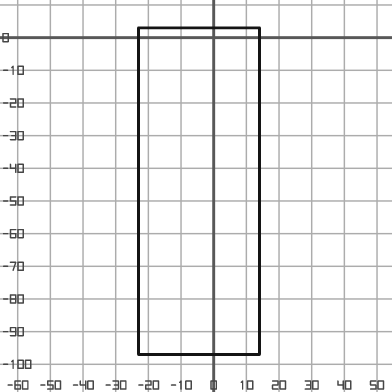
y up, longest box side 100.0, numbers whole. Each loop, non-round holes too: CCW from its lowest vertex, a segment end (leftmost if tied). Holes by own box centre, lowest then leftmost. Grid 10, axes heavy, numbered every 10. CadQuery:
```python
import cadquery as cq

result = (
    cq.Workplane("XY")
    .moveTo(-23.0, -97.0)
    .lineTo(14.0, -97.0)
    .lineTo(14.0, 3.0)
    .lineTo(-23.0, 3.0)
    .close()
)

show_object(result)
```